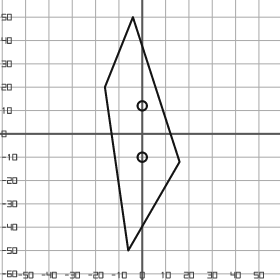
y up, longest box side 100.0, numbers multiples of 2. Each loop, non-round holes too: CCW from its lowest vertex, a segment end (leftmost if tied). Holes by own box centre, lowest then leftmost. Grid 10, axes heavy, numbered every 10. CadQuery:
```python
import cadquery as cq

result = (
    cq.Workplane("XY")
    .moveTo(-6.0, -50.0)
    .lineTo(16.0, -12.0)
    .lineTo(-4.0, 50.0)
    .lineTo(-16.0, 20.0)
    .close()
    .moveTo(0.0, -10.0)
    .circle(2.0)
    .moveTo(0.0, 12.0)
    .circle(2.0)
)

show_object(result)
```